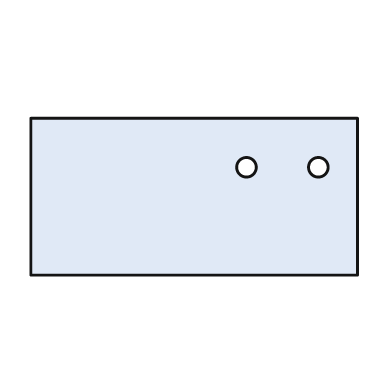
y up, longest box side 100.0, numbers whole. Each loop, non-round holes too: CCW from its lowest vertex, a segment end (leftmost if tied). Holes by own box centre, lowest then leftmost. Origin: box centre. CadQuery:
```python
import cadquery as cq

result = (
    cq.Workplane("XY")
    .moveTo(-50.0, -24.0)
    .lineTo(50.0, -24.0)
    .lineTo(50.0, 24.0)
    .lineTo(-50.0, 24.0)
    .close()
    .moveTo(16.0, 9.0)
    .circle(3.0)
    .moveTo(38.0, 9.0)
    .circle(3.0)
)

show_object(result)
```